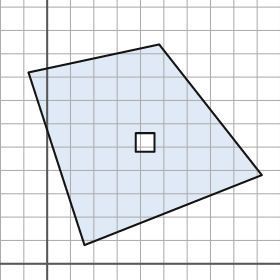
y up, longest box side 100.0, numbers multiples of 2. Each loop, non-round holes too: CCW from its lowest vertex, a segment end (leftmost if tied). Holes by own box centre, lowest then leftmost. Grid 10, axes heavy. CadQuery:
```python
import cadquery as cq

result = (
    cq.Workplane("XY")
    .moveTo(16.0, 8.0)
    .lineTo(92.0, 38.0)
    .lineTo(48.0, 94.0)
    .lineTo(-8.0, 82.0)
    .close()
    .moveTo(38.0, 48.0)
    .lineTo(46.0, 48.0)
    .lineTo(46.0, 56.0)
    .lineTo(38.0, 56.0)
    .close()
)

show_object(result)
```